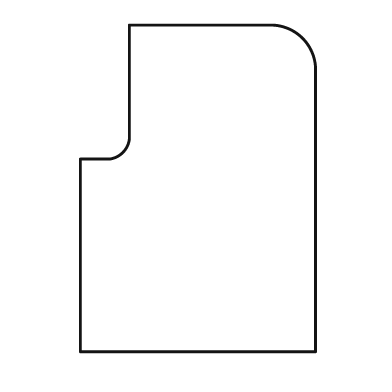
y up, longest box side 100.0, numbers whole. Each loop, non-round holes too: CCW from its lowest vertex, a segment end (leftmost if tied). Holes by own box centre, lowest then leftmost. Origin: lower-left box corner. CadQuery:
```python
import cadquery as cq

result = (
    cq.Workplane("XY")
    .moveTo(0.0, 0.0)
    .lineTo(72.0, 0.0)
    .lineTo(72.0, 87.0)
    .threePointArc((68.0, 96.0), (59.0, 100.0))
    .lineTo(15.0, 100.0)
    .lineTo(15.0, 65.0)
    .threePointArc((13.0, 61.0), (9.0, 59.0))
    .lineTo(0.0, 59.0)
    .close()
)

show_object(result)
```